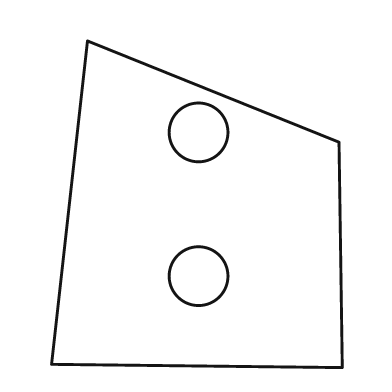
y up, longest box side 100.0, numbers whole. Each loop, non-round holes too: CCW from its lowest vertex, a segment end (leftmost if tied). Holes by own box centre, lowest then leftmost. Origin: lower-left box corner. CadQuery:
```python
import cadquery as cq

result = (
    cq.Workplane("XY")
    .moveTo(89.0, 0.0)
    .lineTo(88.0, 69.0)
    .lineTo(11.0, 100.0)
    .lineTo(0.0, 1.0)
    .close()
    .moveTo(45.0, 28.0)
    .circle(9.0)
    .moveTo(45.0, 72.0)
    .circle(9.0)
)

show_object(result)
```